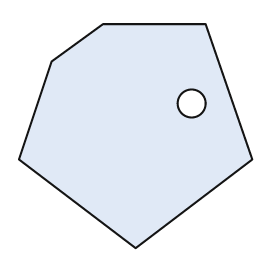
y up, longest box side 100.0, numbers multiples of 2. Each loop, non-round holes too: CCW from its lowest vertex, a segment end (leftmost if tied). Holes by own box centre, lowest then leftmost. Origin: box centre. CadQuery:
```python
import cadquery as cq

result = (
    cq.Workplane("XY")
    .moveTo(0.0, -48.0)
    .lineTo(50.0, -10.0)
    .lineTo(30.0, 48.0)
    .lineTo(-14.0, 48.0)
    .lineTo(-36.0, 32.0)
    .lineTo(-50.0, -10.0)
    .close()
    .moveTo(24.0, 14.0)
    .circle(6.0)
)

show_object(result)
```